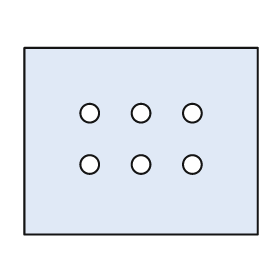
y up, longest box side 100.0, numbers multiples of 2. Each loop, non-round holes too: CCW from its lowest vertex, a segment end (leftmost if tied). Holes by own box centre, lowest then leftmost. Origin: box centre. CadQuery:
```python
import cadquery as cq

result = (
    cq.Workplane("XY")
    .moveTo(-50.0, -40.0)
    .lineTo(50.0, -40.0)
    .lineTo(50.0, 40.0)
    .lineTo(-50.0, 40.0)
    .close()
    .moveTo(-22.0, -10.0)
    .circle(4.0)
    .moveTo(0.0, -10.0)
    .circle(4.0)
    .moveTo(22.0, -10.0)
    .circle(4.0)
    .moveTo(-22.0, 12.0)
    .circle(4.0)
    .moveTo(0.0, 12.0)
    .circle(4.0)
    .moveTo(22.0, 12.0)
    .circle(4.0)
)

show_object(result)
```